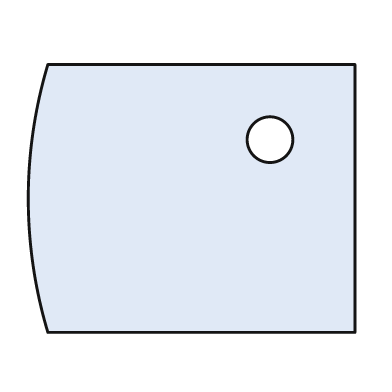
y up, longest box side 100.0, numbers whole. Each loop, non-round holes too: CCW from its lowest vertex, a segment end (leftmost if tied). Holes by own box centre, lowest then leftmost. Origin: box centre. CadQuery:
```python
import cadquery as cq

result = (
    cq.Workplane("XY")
    .moveTo(-44.0, -41.0)
    .lineTo(50.0, -41.0)
    .lineTo(50.0, 41.0)
    .lineTo(-44.0, 41.0)
    .threePointArc((-50.0, 0.0), (-44.0, -41.0))
    .close()
    .moveTo(24.0, 18.0)
    .circle(7.0)
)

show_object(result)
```